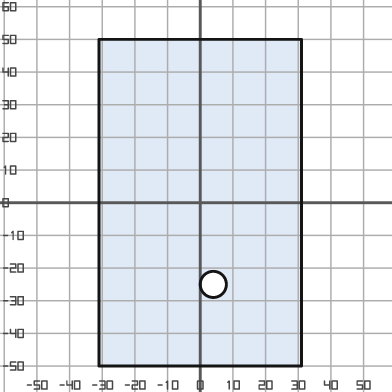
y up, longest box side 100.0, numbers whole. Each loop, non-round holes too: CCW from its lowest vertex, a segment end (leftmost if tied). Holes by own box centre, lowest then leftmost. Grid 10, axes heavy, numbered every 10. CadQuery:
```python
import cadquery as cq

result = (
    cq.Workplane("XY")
    .moveTo(-31.0, -50.0)
    .lineTo(31.0, -50.0)
    .lineTo(31.0, 50.0)
    .lineTo(-31.0, 50.0)
    .close()
    .moveTo(4.0, -25.0)
    .circle(4.0)
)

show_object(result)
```